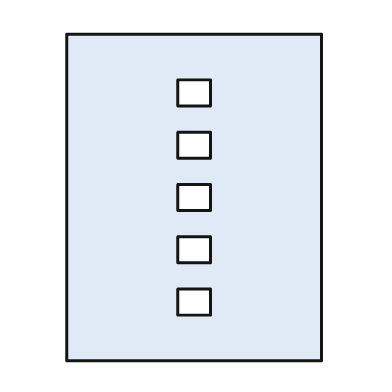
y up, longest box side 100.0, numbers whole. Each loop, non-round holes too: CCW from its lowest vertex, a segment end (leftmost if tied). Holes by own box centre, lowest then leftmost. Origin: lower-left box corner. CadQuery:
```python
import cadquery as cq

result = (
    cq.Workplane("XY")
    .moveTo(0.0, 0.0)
    .lineTo(78.0, 0.0)
    .lineTo(78.0, 100.0)
    .lineTo(0.0, 100.0)
    .close()
    .moveTo(34.0, 14.0)
    .lineTo(44.0, 14.0)
    .lineTo(44.0, 22.0)
    .lineTo(34.0, 22.0)
    .close()
    .moveTo(34.0, 30.0)
    .lineTo(44.0, 30.0)
    .lineTo(44.0, 38.0)
    .lineTo(34.0, 38.0)
    .close()
    .moveTo(34.0, 46.0)
    .lineTo(44.0, 46.0)
    .lineTo(44.0, 54.0)
    .lineTo(34.0, 54.0)
    .close()
    .moveTo(34.0, 62.0)
    .lineTo(44.0, 62.0)
    .lineTo(44.0, 70.0)
    .lineTo(34.0, 70.0)
    .close()
    .moveTo(34.0, 78.0)
    .lineTo(44.0, 78.0)
    .lineTo(44.0, 86.0)
    .lineTo(34.0, 86.0)
    .close()
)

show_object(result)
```